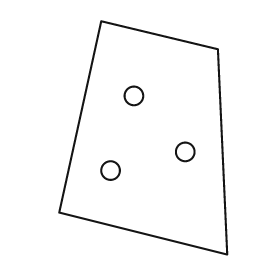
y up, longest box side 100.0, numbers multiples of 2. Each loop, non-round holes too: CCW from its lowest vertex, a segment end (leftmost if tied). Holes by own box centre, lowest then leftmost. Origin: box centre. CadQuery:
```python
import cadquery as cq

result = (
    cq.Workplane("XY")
    .moveTo(36.0, -50.0)
    .lineTo(32.0, 38.0)
    .lineTo(-18.0, 50.0)
    .lineTo(-36.0, -32.0)
    .close()
    .moveTo(-14.0, -14.0)
    .circle(4.0)
    .moveTo(18.0, -6.0)
    .circle(4.0)
    .moveTo(-4.0, 18.0)
    .circle(4.0)
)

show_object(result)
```